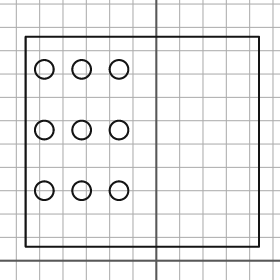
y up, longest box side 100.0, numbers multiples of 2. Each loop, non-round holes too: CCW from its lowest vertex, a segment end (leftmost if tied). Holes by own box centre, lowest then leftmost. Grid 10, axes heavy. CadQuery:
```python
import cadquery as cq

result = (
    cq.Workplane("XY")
    .moveTo(-56.0, 6.0)
    .lineTo(44.0, 6.0)
    .lineTo(44.0, 96.0)
    .lineTo(-56.0, 96.0)
    .close()
    .moveTo(-48.0, 30.0)
    .circle(4.0)
    .moveTo(-32.0, 30.0)
    .circle(4.0)
    .moveTo(-16.0, 30.0)
    .circle(4.0)
    .moveTo(-48.0, 56.0)
    .circle(4.0)
    .moveTo(-32.0, 56.0)
    .circle(4.0)
    .moveTo(-16.0, 56.0)
    .circle(4.0)
    .moveTo(-48.0, 82.0)
    .circle(4.0)
    .moveTo(-32.0, 82.0)
    .circle(4.0)
    .moveTo(-16.0, 82.0)
    .circle(4.0)
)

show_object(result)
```